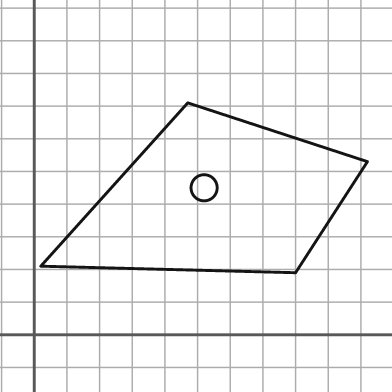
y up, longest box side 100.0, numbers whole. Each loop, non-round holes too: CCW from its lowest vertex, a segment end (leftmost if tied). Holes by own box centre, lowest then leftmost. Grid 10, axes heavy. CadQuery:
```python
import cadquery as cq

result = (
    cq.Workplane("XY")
    .moveTo(80.0, 19.0)
    .lineTo(102.0, 53.0)
    .lineTo(47.0, 71.0)
    .lineTo(2.0, 21.0)
    .close()
    .moveTo(52.0, 45.0)
    .circle(4.0)
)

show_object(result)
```